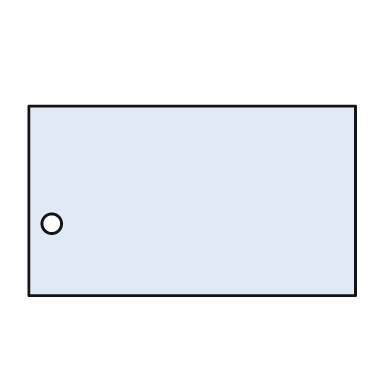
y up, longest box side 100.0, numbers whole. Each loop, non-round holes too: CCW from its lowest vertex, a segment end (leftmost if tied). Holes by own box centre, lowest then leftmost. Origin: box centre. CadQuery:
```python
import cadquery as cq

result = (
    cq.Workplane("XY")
    .moveTo(-50.0, -29.0)
    .lineTo(50.0, -29.0)
    .lineTo(50.0, 29.0)
    .lineTo(-50.0, 29.0)
    .close()
    .moveTo(-43.0, -7.0)
    .circle(3.0)
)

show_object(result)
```